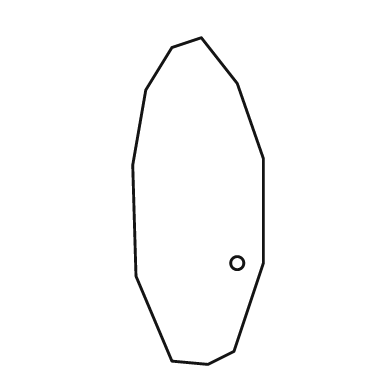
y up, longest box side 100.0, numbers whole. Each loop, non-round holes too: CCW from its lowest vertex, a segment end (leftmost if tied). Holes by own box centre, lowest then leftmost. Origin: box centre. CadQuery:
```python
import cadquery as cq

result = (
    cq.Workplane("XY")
    .moveTo(3.0, -50.0)
    .lineTo(11.0, -46.0)
    .lineTo(20.0, -19.0)
    .lineTo(20.0, 13.0)
    .lineTo(12.0, 36.0)
    .lineTo(1.0, 50.0)
    .lineTo(-8.0, 47.0)
    .lineTo(-16.0, 34.0)
    .lineTo(-20.0, 11.0)
    .lineTo(-19.0, -23.0)
    .lineTo(-8.0, -49.0)
    .close()
    .moveTo(12.0, -19.0)
    .circle(2.0)
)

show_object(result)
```